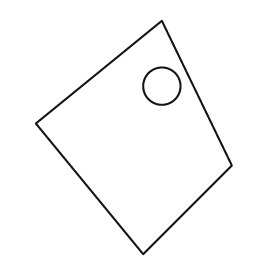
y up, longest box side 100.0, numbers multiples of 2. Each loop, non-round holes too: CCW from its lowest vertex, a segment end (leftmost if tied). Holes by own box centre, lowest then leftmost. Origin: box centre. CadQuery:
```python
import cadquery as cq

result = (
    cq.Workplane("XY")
    .moveTo(4.0, -50.0)
    .lineTo(42.0, -12.0)
    .lineTo(12.0, 50.0)
    .lineTo(-42.0, 6.0)
    .close()
    .moveTo(12.0, 22.0)
    .circle(8.0)
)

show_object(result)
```